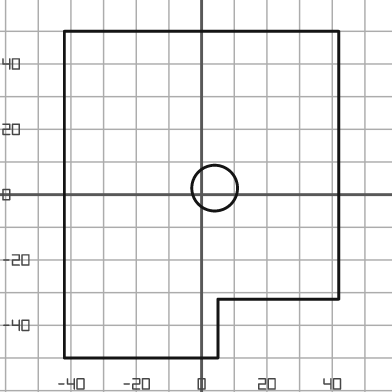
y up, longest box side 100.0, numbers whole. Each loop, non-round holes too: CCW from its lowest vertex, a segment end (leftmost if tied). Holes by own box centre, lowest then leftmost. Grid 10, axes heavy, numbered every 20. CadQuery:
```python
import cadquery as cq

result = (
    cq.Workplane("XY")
    .moveTo(-42.0, -50.0)
    .lineTo(5.0, -50.0)
    .lineTo(5.0, -32.0)
    .lineTo(42.0, -32.0)
    .lineTo(42.0, 50.0)
    .lineTo(-42.0, 50.0)
    .close()
    .moveTo(4.0, 2.0)
    .circle(7.0)
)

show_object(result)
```